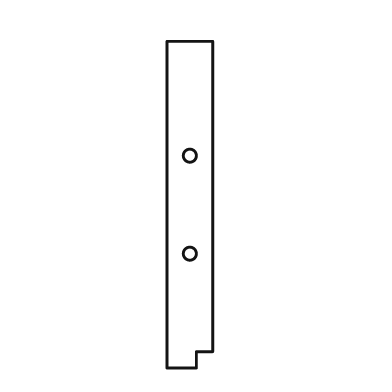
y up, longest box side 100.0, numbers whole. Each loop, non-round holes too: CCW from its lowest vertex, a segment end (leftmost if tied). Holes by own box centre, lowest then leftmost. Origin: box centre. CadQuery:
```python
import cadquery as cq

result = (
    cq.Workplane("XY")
    .moveTo(-7.0, -50.0)
    .lineTo(2.0, -50.0)
    .lineTo(2.0, -45.0)
    .lineTo(7.0, -45.0)
    .lineTo(7.0, 50.0)
    .lineTo(-7.0, 50.0)
    .close()
    .moveTo(0.0, -15.0)
    .circle(2.0)
    .moveTo(0.0, 15.0)
    .circle(2.0)
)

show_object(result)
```